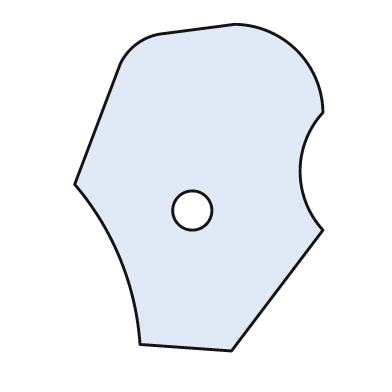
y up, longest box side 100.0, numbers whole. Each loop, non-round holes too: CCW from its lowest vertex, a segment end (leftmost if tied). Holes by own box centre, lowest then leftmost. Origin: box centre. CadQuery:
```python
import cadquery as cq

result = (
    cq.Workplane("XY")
    .moveTo(10.0, -50.0)
    .lineTo(38.0, -13.0)
    .threePointArc((31.0, 5.0), (38.0, 23.0))
    .threePointArc((30.0, 42.0), (11.0, 50.0))
    .lineTo(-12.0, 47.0)
    .threePointArc((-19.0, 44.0), (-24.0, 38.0))
    .lineTo(-38.0, 1.0)
    .threePointArc((-24.0, -22.0), (-18.0, -48.0))
    .close()
    .moveTo(-2.0, -7.0)
    .circle(6.0)
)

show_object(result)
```